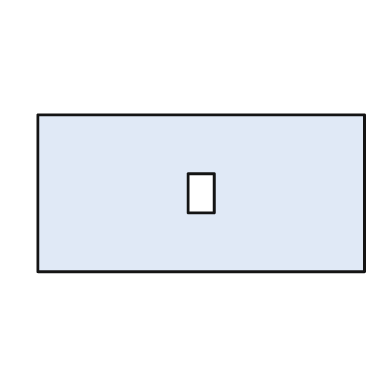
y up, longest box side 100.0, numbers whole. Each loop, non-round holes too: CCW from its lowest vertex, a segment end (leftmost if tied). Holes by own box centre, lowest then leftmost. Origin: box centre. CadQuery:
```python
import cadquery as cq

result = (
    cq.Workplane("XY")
    .moveTo(-50.0, -24.0)
    .lineTo(50.0, -24.0)
    .lineTo(50.0, 24.0)
    .lineTo(-50.0, 24.0)
    .close()
    .moveTo(-4.0, -6.0)
    .lineTo(4.0, -6.0)
    .lineTo(4.0, 6.0)
    .lineTo(-4.0, 6.0)
    .close()
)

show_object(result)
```